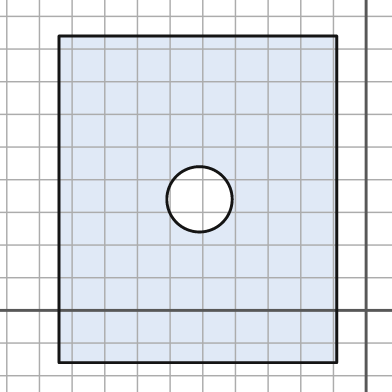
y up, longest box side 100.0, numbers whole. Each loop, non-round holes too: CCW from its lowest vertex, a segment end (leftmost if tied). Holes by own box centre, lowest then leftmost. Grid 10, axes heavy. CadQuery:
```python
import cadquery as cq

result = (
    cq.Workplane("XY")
    .moveTo(-94.0, -16.0)
    .lineTo(-9.0, -16.0)
    .lineTo(-9.0, 84.0)
    .lineTo(-94.0, 84.0)
    .close()
    .moveTo(-51.0, 34.0)
    .circle(10.0)
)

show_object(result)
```